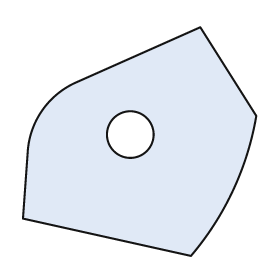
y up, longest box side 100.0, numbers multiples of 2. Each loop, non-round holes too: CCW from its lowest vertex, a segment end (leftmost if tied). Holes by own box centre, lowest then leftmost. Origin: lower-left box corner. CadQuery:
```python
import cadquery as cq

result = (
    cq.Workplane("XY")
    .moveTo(72.0, 0.0)
    .threePointArc((90.0, 28.0), (100.0, 60.0))
    .lineTo(76.0, 98.0)
    .lineTo(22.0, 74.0)
    .threePointArc((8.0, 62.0), (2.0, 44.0))
    .lineTo(0.0, 16.0)
    .close()
    .moveTo(46.0, 52.0)
    .circle(10.0)
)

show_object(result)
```